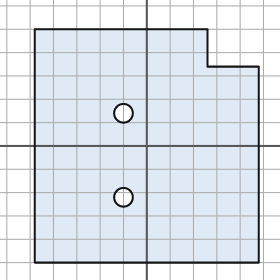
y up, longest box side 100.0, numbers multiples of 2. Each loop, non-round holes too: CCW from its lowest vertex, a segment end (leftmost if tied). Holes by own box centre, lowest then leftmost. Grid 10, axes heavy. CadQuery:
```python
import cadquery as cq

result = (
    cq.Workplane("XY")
    .moveTo(-48.0, -50.0)
    .lineTo(48.0, -50.0)
    .lineTo(48.0, 34.0)
    .lineTo(26.0, 34.0)
    .lineTo(26.0, 50.0)
    .lineTo(-48.0, 50.0)
    .close()
    .moveTo(-10.0, -22.0)
    .circle(4.0)
    .moveTo(-10.0, 14.0)
    .circle(4.0)
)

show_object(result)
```